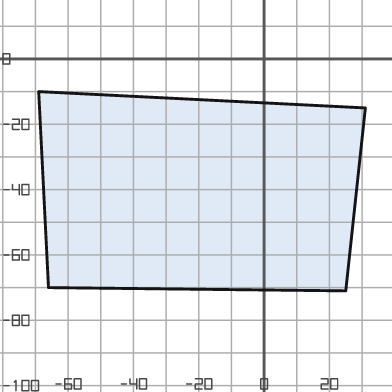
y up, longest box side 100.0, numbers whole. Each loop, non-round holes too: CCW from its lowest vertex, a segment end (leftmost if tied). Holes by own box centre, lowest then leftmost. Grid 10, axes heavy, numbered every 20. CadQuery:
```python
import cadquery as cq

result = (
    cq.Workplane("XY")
    .moveTo(25.0, -71.0)
    .lineTo(31.0, -15.0)
    .lineTo(-69.0, -10.0)
    .lineTo(-66.0, -70.0)
    .close()
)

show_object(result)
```